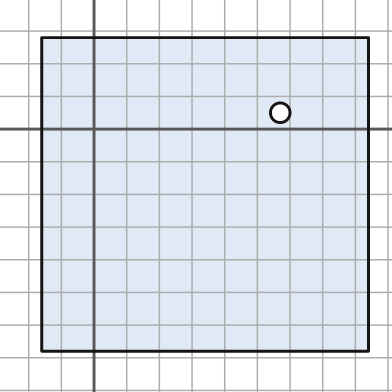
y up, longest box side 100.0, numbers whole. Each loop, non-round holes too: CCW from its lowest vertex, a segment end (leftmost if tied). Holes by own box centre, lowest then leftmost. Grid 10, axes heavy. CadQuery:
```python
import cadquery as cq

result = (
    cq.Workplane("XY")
    .moveTo(-16.0, -68.0)
    .lineTo(84.0, -68.0)
    .lineTo(84.0, 28.0)
    .lineTo(-16.0, 28.0)
    .close()
    .moveTo(57.0, 5.0)
    .circle(3.0)
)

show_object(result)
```